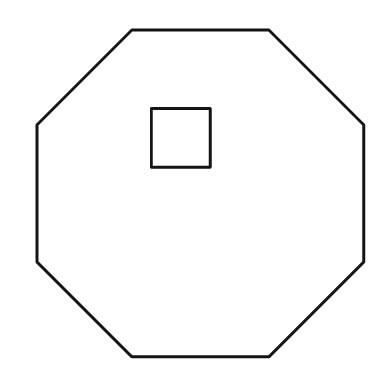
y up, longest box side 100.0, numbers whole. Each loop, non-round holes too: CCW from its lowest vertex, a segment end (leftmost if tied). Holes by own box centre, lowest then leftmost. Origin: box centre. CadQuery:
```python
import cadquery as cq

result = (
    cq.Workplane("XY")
    .moveTo(-21.0, -50.0)
    .lineTo(21.0, -50.0)
    .lineTo(50.0, -21.0)
    .lineTo(50.0, 21.0)
    .lineTo(21.0, 50.0)
    .lineTo(-21.0, 50.0)
    .lineTo(-50.0, 21.0)
    .lineTo(-50.0, -21.0)
    .close()
    .moveTo(-15.0, 8.0)
    .lineTo(3.0, 8.0)
    .lineTo(3.0, 26.0)
    .lineTo(-15.0, 26.0)
    .close()
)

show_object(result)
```